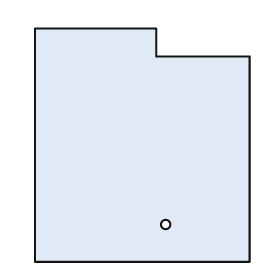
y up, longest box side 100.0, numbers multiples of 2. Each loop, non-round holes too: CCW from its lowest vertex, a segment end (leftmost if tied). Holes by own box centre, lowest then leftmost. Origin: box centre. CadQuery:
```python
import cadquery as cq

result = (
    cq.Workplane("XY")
    .moveTo(-46.0, -50.0)
    .lineTo(46.0, -50.0)
    .lineTo(46.0, 38.0)
    .lineTo(6.0, 38.0)
    .lineTo(6.0, 50.0)
    .lineTo(-46.0, 50.0)
    .close()
    .moveTo(10.0, -34.0)
    .circle(2.0)
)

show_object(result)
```